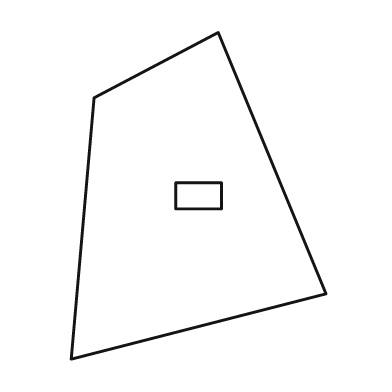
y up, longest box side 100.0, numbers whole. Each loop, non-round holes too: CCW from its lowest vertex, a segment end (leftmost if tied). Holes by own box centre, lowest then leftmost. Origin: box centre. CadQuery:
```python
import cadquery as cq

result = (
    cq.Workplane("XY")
    .moveTo(-39.0, -50.0)
    .lineTo(39.0, -30.0)
    .lineTo(6.0, 50.0)
    .lineTo(-32.0, 30.0)
    .close()
    .moveTo(-7.0, -4.0)
    .lineTo(7.0, -4.0)
    .lineTo(7.0, 4.0)
    .lineTo(-7.0, 4.0)
    .close()
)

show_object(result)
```